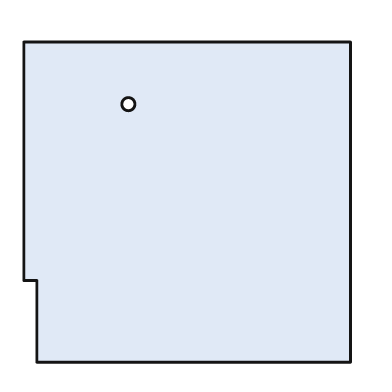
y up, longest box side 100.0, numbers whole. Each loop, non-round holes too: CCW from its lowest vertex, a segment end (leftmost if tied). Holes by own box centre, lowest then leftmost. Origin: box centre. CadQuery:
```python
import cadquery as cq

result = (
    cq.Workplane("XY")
    .moveTo(-46.0, -49.0)
    .lineTo(50.0, -49.0)
    .lineTo(50.0, 49.0)
    .lineTo(-50.0, 49.0)
    .lineTo(-50.0, -24.0)
    .lineTo(-46.0, -24.0)
    .close()
    .moveTo(-18.0, 30.0)
    .circle(2.0)
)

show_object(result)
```